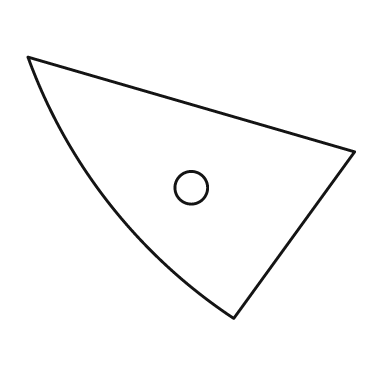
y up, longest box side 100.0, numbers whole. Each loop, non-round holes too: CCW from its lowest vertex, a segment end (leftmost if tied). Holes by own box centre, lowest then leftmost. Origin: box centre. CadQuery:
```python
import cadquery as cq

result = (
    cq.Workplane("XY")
    .moveTo(13.0, -40.0)
    .lineTo(50.0, 11.0)
    .lineTo(-50.0, 40.0)
    .threePointArc((-25.0, -5.0), (13.0, -40.0))
    .close()
    .moveTo(0.0, 0.0)
    .circle(5.0)
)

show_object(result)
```